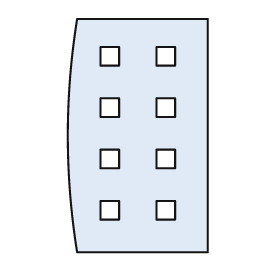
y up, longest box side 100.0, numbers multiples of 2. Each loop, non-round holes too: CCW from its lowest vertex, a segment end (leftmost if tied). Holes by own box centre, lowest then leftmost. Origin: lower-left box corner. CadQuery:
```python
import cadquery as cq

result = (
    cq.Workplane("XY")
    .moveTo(4.0, 0.0)
    .lineTo(60.0, 0.0)
    .lineTo(60.0, 100.0)
    .lineTo(4.0, 100.0)
    .threePointArc((0.0, 50.0), (4.0, 0.0))
    .close()
    .moveTo(14.0, 14.0)
    .lineTo(22.0, 14.0)
    .lineTo(22.0, 22.0)
    .lineTo(14.0, 22.0)
    .close()
    .moveTo(38.0, 14.0)
    .lineTo(46.0, 14.0)
    .lineTo(46.0, 22.0)
    .lineTo(38.0, 22.0)
    .close()
    .moveTo(14.0, 36.0)
    .lineTo(22.0, 36.0)
    .lineTo(22.0, 44.0)
    .lineTo(14.0, 44.0)
    .close()
    .moveTo(38.0, 36.0)
    .lineTo(46.0, 36.0)
    .lineTo(46.0, 44.0)
    .lineTo(38.0, 44.0)
    .close()
    .moveTo(14.0, 58.0)
    .lineTo(22.0, 58.0)
    .lineTo(22.0, 66.0)
    .lineTo(14.0, 66.0)
    .close()
    .moveTo(38.0, 58.0)
    .lineTo(46.0, 58.0)
    .lineTo(46.0, 66.0)
    .lineTo(38.0, 66.0)
    .close()
    .moveTo(14.0, 80.0)
    .lineTo(22.0, 80.0)
    .lineTo(22.0, 88.0)
    .lineTo(14.0, 88.0)
    .close()
    .moveTo(38.0, 80.0)
    .lineTo(46.0, 80.0)
    .lineTo(46.0, 88.0)
    .lineTo(38.0, 88.0)
    .close()
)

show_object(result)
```